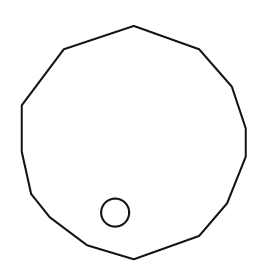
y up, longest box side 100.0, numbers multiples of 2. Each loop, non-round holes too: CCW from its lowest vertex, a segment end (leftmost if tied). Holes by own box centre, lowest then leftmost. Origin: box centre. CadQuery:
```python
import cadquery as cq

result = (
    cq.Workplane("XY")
    .moveTo(0.0, -50.0)
    .lineTo(28.0, -40.0)
    .lineTo(40.0, -26.0)
    .lineTo(48.0, -6.0)
    .lineTo(48.0, 6.0)
    .lineTo(42.0, 24.0)
    .lineTo(28.0, 40.0)
    .lineTo(0.0, 50.0)
    .lineTo(-30.0, 40.0)
    .lineTo(-48.0, 16.0)
    .lineTo(-48.0, -4.0)
    .lineTo(-44.0, -22.0)
    .lineTo(-36.0, -32.0)
    .lineTo(-20.0, -44.0)
    .close()
    .moveTo(-8.0, -30.0)
    .circle(6.0)
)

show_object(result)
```